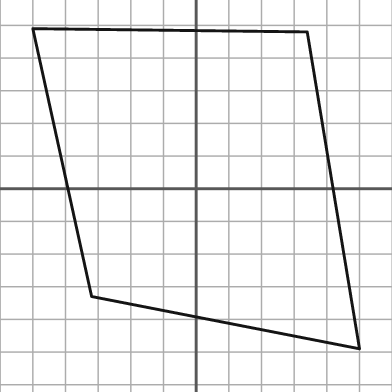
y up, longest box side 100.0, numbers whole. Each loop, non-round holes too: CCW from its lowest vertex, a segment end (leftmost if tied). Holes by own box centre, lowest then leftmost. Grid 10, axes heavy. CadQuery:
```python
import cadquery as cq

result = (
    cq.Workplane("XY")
    .moveTo(50.0, -49.0)
    .lineTo(34.0, 48.0)
    .lineTo(-50.0, 49.0)
    .lineTo(-32.0, -33.0)
    .close()
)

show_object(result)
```